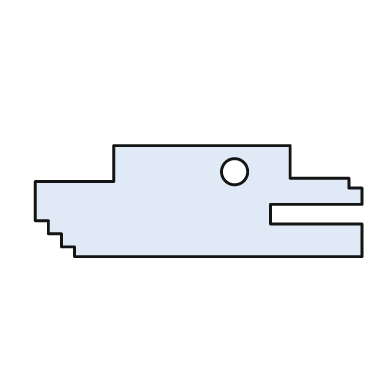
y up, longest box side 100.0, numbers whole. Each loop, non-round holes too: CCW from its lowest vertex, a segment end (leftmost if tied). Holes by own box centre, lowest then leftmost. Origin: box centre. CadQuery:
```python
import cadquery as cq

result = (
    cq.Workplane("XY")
    .moveTo(-38.0, -17.0)
    .lineTo(50.0, -17.0)
    .lineTo(50.0, -7.0)
    .lineTo(22.0, -7.0)
    .lineTo(22.0, -1.0)
    .lineTo(50.0, -1.0)
    .lineTo(50.0, 4.0)
    .lineTo(46.0, 4.0)
    .lineTo(46.0, 7.0)
    .lineTo(28.0, 7.0)
    .lineTo(28.0, 17.0)
    .lineTo(-26.0, 17.0)
    .lineTo(-26.0, 6.0)
    .lineTo(-50.0, 6.0)
    .lineTo(-50.0, -6.0)
    .lineTo(-46.0, -6.0)
    .lineTo(-46.0, -10.0)
    .lineTo(-42.0, -10.0)
    .lineTo(-42.0, -14.0)
    .lineTo(-38.0, -14.0)
    .close()
    .moveTo(11.0, 9.0)
    .circle(4.0)
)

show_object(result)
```